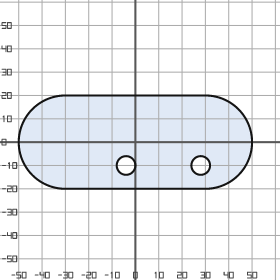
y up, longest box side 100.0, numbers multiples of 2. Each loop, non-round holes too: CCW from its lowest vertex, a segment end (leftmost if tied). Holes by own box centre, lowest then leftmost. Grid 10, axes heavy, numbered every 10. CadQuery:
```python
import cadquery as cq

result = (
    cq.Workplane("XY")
    .moveTo(-30.0, -20.0)
    .lineTo(30.0, -20.0)
    .threePointArc((50.0, 0.0), (30.0, 20.0))
    .lineTo(-30.0, 20.0)
    .threePointArc((-50.0, 0.0), (-30.0, -20.0))
    .close()
    .moveTo(-4.0, -10.0)
    .circle(4.0)
    .moveTo(28.0, -10.0)
    .circle(4.0)
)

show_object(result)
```